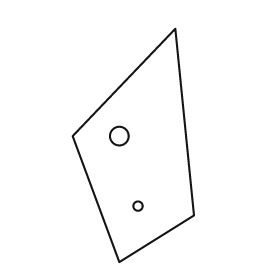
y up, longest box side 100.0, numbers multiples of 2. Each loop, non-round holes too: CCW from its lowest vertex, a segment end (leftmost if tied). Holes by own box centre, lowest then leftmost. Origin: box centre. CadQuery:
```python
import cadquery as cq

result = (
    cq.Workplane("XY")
    .moveTo(-6.0, -50.0)
    .lineTo(26.0, -30.0)
    .lineTo(18.0, 50.0)
    .lineTo(-26.0, 4.0)
    .close()
    .moveTo(2.0, -26.0)
    .circle(2.0)
    .moveTo(-6.0, 4.0)
    .circle(4.0)
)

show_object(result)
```